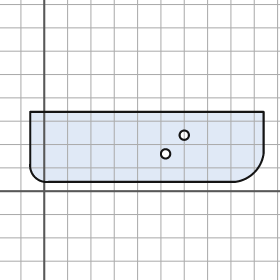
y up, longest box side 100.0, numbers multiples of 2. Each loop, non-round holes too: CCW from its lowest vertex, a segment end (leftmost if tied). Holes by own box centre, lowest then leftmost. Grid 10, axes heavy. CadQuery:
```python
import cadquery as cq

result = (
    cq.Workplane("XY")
    .moveTo(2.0, 4.0)
    .lineTo(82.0, 4.0)
    .threePointArc((90.0, 8.0), (94.0, 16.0))
    .lineTo(94.0, 34.0)
    .lineTo(-6.0, 34.0)
    .lineTo(-6.0, 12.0)
    .threePointArc((-4.0, 6.0), (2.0, 4.0))
    .close()
    .moveTo(52.0, 16.0)
    .circle(2.0)
    .moveTo(60.0, 24.0)
    .circle(2.0)
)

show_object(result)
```